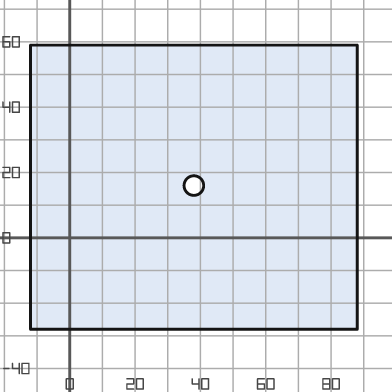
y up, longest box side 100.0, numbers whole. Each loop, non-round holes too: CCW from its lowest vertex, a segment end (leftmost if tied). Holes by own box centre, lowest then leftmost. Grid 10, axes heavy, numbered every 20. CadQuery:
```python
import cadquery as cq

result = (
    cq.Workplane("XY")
    .moveTo(-12.0, -28.0)
    .lineTo(88.0, -28.0)
    .lineTo(88.0, 59.0)
    .lineTo(-12.0, 59.0)
    .close()
    .moveTo(38.0, 16.0)
    .circle(3.0)
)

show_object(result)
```